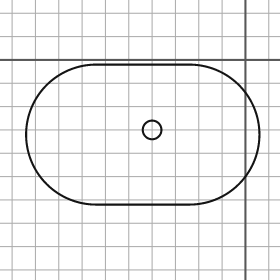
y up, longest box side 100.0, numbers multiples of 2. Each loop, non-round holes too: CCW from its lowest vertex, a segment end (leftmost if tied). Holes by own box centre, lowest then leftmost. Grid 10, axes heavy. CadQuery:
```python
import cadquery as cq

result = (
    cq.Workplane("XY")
    .moveTo(-64.0, -62.0)
    .lineTo(-24.0, -62.0)
    .threePointArc((6.0, -32.0), (-24.0, -2.0))
    .lineTo(-64.0, -2.0)
    .threePointArc((-94.0, -32.0), (-64.0, -62.0))
    .close()
    .moveTo(-40.0, -30.0)
    .circle(4.0)
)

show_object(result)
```